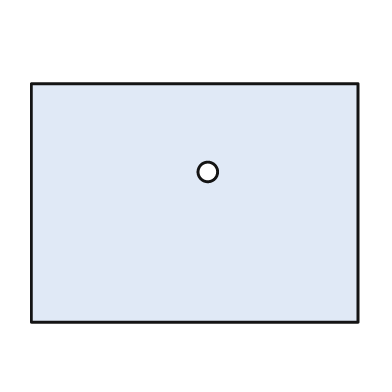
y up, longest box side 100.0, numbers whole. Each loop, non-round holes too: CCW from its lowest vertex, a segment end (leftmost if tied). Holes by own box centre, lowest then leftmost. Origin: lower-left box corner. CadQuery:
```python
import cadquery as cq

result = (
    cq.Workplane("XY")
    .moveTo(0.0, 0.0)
    .lineTo(100.0, 0.0)
    .lineTo(100.0, 73.0)
    .lineTo(0.0, 73.0)
    .close()
    .moveTo(54.0, 46.0)
    .circle(3.0)
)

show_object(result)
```